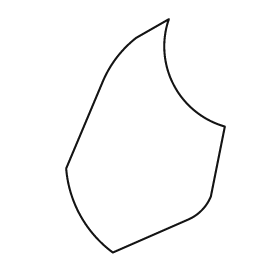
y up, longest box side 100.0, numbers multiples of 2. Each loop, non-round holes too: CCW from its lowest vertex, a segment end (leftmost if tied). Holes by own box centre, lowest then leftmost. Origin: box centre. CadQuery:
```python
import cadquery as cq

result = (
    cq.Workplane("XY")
    .moveTo(-14.0, -50.0)
    .lineTo(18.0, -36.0)
    .threePointArc((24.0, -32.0), (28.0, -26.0))
    .lineTo(34.0, 4.0)
    .threePointArc((12.0, 22.0), (10.0, 50.0))
    .lineTo(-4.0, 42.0)
    .threePointArc((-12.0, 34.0), (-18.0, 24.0))
    .lineTo(-34.0, -14.0)
    .threePointArc((-28.0, -34.0), (-14.0, -50.0))
    .close()
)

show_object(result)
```